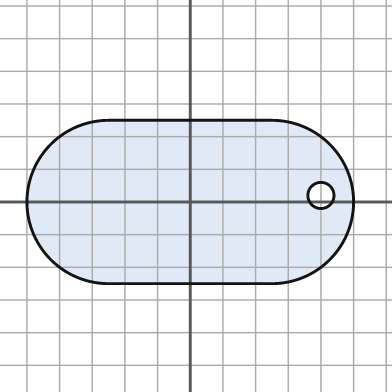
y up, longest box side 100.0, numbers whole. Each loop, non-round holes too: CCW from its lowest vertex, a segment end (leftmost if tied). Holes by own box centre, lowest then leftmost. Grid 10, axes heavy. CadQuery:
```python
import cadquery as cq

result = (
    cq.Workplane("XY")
    .moveTo(-25.0, -25.0)
    .lineTo(25.0, -25.0)
    .threePointArc((50.0, 0.0), (25.0, 25.0))
    .lineTo(-25.0, 25.0)
    .threePointArc((-50.0, 0.0), (-25.0, -25.0))
    .close()
    .moveTo(40.0, 2.0)
    .circle(4.0)
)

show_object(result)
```